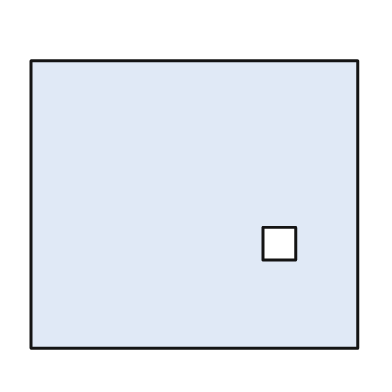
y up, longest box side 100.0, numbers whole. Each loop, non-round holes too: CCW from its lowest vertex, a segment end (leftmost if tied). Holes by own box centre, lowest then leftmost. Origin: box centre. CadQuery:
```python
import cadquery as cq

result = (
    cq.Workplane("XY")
    .moveTo(-50.0, -44.0)
    .lineTo(50.0, -44.0)
    .lineTo(50.0, 44.0)
    .lineTo(-50.0, 44.0)
    .close()
    .moveTo(21.0, -17.0)
    .lineTo(31.0, -17.0)
    .lineTo(31.0, -7.0)
    .lineTo(21.0, -7.0)
    .close()
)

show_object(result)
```